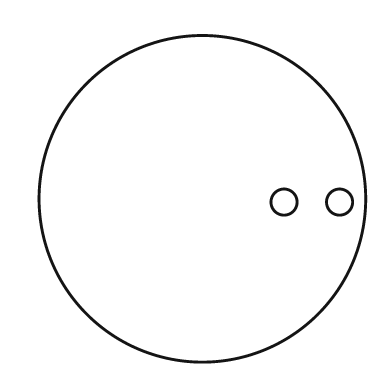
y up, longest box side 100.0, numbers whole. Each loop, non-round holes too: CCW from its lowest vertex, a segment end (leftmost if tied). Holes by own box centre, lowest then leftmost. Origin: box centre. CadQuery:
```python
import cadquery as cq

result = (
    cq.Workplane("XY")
    .moveTo(0.0, 0.0)
    .circle(50.0)
    .moveTo(25.0, -1.0)
    .circle(4.0)
    .moveTo(42.0, -1.0)
    .circle(4.0)
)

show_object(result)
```